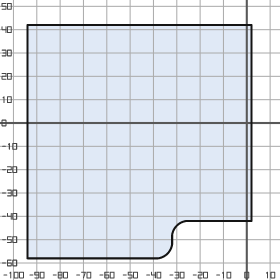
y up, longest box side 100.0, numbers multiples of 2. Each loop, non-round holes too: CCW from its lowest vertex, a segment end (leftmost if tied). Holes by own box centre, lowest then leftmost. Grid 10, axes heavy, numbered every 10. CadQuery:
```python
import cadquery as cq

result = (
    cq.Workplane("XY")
    .moveTo(-94.0, -58.0)
    .lineTo(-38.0, -58.0)
    .threePointArc((-34.0, -56.0), (-32.0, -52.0))
    .lineTo(-32.0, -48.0)
    .threePointArc((-30.0, -44.0), (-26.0, -42.0))
    .lineTo(2.0, -42.0)
    .lineTo(2.0, 42.0)
    .lineTo(-94.0, 42.0)
    .close()
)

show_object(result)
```